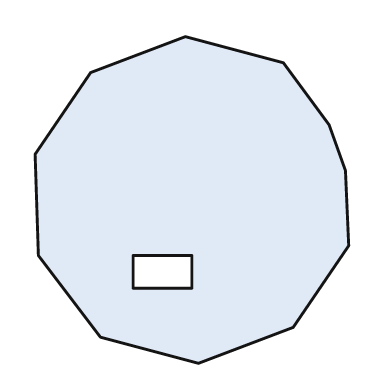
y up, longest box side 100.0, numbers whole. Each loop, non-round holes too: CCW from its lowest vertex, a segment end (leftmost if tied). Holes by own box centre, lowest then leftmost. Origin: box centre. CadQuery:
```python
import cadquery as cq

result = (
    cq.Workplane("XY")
    .moveTo(2.0, -50.0)
    .lineTo(31.0, -39.0)
    .lineTo(48.0, -14.0)
    .lineTo(47.0, 9.0)
    .lineTo(42.0, 23.0)
    .lineTo(28.0, 42.0)
    .lineTo(-2.0, 50.0)
    .lineTo(-31.0, 39.0)
    .lineTo(-48.0, 14.0)
    .lineTo(-47.0, -17.0)
    .lineTo(-28.0, -42.0)
    .close()
    .moveTo(-18.0, -27.0)
    .lineTo(0.0, -27.0)
    .lineTo(0.0, -17.0)
    .lineTo(-18.0, -17.0)
    .close()
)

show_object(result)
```